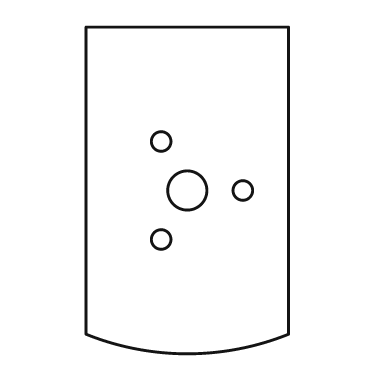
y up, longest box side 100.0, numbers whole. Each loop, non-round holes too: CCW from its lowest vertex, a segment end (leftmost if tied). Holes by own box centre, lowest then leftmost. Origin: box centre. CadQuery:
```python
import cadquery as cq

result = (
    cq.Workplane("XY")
    .moveTo(-31.0, -44.0)
    .threePointArc((0.0, -50.0), (31.0, -44.0))
    .lineTo(31.0, 50.0)
    .lineTo(-31.0, 50.0)
    .close()
    .moveTo(-8.0, -15.0)
    .circle(3.0)
    .moveTo(0.0, 0.0)
    .circle(6.0)
    .moveTo(17.0, 0.0)
    .circle(3.0)
    .moveTo(-8.0, 15.0)
    .circle(3.0)
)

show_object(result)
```